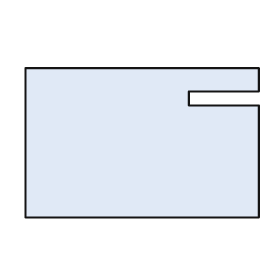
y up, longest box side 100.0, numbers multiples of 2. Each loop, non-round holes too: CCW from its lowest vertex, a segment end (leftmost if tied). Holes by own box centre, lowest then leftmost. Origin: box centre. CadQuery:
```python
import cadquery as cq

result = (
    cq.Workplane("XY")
    .moveTo(-50.0, -32.0)
    .lineTo(50.0, -32.0)
    .lineTo(50.0, 16.0)
    .lineTo(20.0, 16.0)
    .lineTo(20.0, 22.0)
    .lineTo(50.0, 22.0)
    .lineTo(50.0, 32.0)
    .lineTo(-50.0, 32.0)
    .close()
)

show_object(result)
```